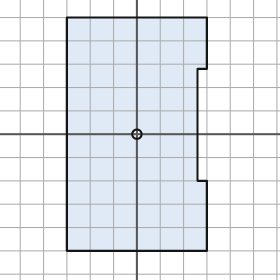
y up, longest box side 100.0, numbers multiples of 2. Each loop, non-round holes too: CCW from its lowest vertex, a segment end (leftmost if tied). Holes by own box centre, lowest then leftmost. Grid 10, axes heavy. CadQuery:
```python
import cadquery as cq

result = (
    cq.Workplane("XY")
    .moveTo(-30.0, -50.0)
    .lineTo(30.0, -50.0)
    .lineTo(30.0, -20.0)
    .lineTo(26.0, -20.0)
    .lineTo(26.0, 28.0)
    .lineTo(30.0, 28.0)
    .lineTo(30.0, 50.0)
    .lineTo(-30.0, 50.0)
    .close()
    .moveTo(0.0, 0.0)
    .circle(2.0)
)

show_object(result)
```